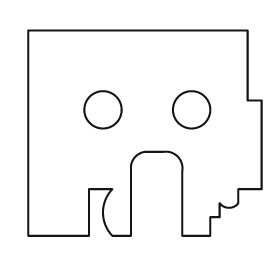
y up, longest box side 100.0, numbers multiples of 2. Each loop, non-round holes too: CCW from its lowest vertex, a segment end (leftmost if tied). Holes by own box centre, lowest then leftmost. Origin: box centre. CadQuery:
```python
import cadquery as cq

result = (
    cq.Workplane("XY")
    .moveTo(-50.0, -44.0)
    .lineTo(-24.0, -44.0)
    .lineTo(-24.0, -24.0)
    .lineTo(-14.0, -24.0)
    .threePointArc((-18.0, -34.0), (-14.0, -44.0))
    .lineTo(-6.0, -44.0)
    .lineTo(-6.0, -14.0)
    .threePointArc((-4.0, -10.0), (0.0, -8.0))
    .lineTo(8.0, -8.0)
    .threePointArc((14.0, -10.0), (16.0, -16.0))
    .lineTo(16.0, -44.0)
    .lineTo(28.0, -44.0)
    .lineTo(28.0, -36.0)
    .lineTo(32.0, -36.0)
    .lineTo(32.0, -30.0)
    .threePointArc((36.0, -32.0), (40.0, -30.0))
    .lineTo(40.0, -24.0)
    .lineTo(50.0, -24.0)
    .lineTo(50.0, 14.0)
    .lineTo(44.0, 14.0)
    .lineTo(44.0, 44.0)
    .lineTo(-50.0, 44.0)
    .close()
    .moveTo(-18.0, 10.0)
    .circle(8.0)
    .moveTo(20.0, 10.0)
    .circle(8.0)
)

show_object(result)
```